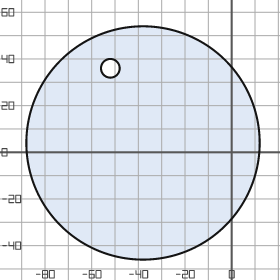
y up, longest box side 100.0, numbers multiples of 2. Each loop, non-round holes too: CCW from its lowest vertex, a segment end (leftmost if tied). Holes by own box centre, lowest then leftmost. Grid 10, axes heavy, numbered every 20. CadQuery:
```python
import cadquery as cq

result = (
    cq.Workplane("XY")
    .moveTo(-38.0, 4.0)
    .circle(50.0)
    .moveTo(-52.0, 36.0)
    .circle(4.0)
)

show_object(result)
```